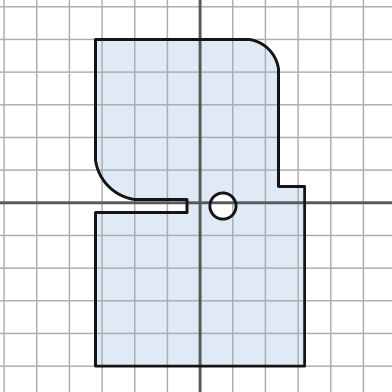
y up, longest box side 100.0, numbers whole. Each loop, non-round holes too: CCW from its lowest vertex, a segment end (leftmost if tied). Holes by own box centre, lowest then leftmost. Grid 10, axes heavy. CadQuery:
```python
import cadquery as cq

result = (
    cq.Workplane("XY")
    .moveTo(-32.0, -50.0)
    .lineTo(32.0, -50.0)
    .lineTo(32.0, 5.0)
    .lineTo(24.0, 5.0)
    .lineTo(24.0, 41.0)
    .threePointArc((21.0, 47.0), (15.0, 50.0))
    .lineTo(-32.0, 50.0)
    .lineTo(-32.0, 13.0)
    .threePointArc((-28.0, 5.0), (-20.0, 1.0))
    .lineTo(-4.0, 1.0)
    .lineTo(-4.0, -3.0)
    .lineTo(-32.0, -3.0)
    .close()
    .moveTo(7.0, -1.0)
    .circle(4.0)
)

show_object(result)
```